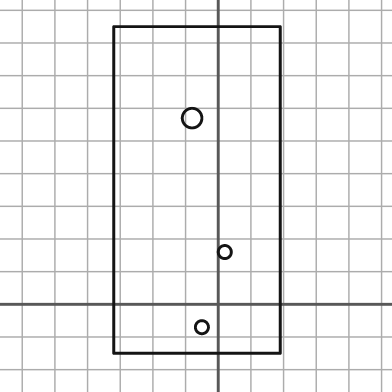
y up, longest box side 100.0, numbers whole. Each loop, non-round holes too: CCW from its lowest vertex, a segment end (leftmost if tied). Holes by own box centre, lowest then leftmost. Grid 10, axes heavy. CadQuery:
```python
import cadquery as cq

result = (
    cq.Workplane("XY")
    .moveTo(-32.0, -15.0)
    .lineTo(19.0, -15.0)
    .lineTo(19.0, 85.0)
    .lineTo(-32.0, 85.0)
    .close()
    .moveTo(-5.0, -7.0)
    .circle(2.0)
    .moveTo(2.0, 16.0)
    .circle(2.0)
    .moveTo(-8.0, 57.0)
    .circle(3.0)
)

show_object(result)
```